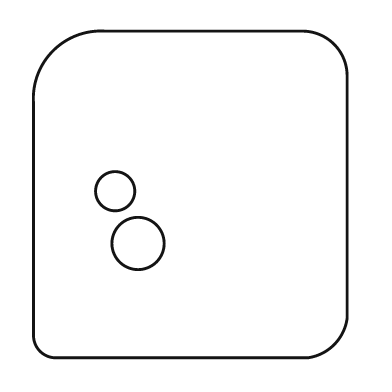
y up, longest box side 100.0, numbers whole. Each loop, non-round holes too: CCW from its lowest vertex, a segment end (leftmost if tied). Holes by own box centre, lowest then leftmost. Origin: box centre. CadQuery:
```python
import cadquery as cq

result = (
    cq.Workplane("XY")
    .moveTo(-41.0, -50.0)
    .lineTo(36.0, -50.0)
    .threePointArc((44.0, -46.0), (48.0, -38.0))
    .lineTo(48.0, 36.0)
    .threePointArc((44.0, 46.0), (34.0, 50.0))
    .lineTo(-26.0, 50.0)
    .threePointArc((-42.0, 44.0), (-48.0, 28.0))
    .lineTo(-48.0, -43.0)
    .threePointArc((-46.0, -48.0), (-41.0, -50.0))
    .close()
    .moveTo(-16.0, -15.0)
    .circle(8.0)
    .moveTo(-23.0, 1.0)
    .circle(6.0)
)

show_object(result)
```